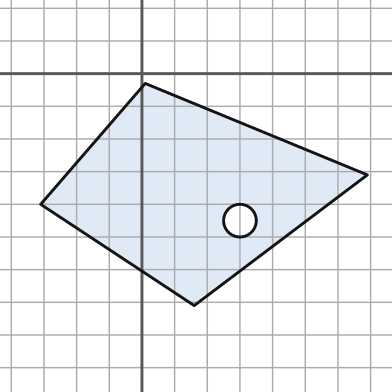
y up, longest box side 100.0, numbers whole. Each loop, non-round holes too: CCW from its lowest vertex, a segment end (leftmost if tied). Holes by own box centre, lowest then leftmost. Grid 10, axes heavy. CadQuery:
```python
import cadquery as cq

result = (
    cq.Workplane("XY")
    .moveTo(16.0, -71.0)
    .lineTo(69.0, -31.0)
    .lineTo(1.0, -3.0)
    .lineTo(-31.0, -40.0)
    .close()
    .moveTo(30.0, -45.0)
    .circle(5.0)
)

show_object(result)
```